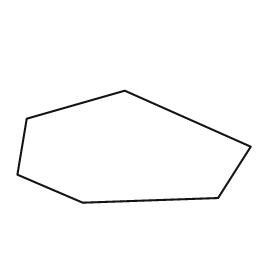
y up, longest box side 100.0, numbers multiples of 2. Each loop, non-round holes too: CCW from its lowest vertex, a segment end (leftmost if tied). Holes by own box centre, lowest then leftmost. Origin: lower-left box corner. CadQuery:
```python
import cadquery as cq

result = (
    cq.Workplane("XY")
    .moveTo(28.0, 0.0)
    .lineTo(86.0, 2.0)
    .lineTo(100.0, 24.0)
    .lineTo(46.0, 48.0)
    .lineTo(4.0, 36.0)
    .lineTo(0.0, 12.0)
    .close()
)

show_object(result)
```